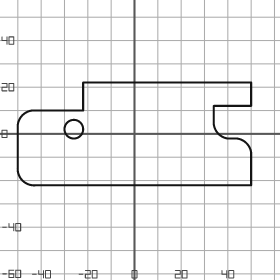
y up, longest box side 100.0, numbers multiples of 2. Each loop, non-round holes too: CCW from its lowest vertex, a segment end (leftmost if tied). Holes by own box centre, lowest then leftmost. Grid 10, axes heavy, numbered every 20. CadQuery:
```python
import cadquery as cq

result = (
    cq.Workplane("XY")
    .moveTo(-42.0, -22.0)
    .lineTo(50.0, -22.0)
    .lineTo(50.0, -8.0)
    .threePointArc((48.0, -4.0), (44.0, -2.0))
    .lineTo(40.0, -2.0)
    .threePointArc((36.0, 0.0), (34.0, 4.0))
    .lineTo(34.0, 12.0)
    .lineTo(50.0, 12.0)
    .lineTo(50.0, 22.0)
    .lineTo(-22.0, 22.0)
    .lineTo(-22.0, 10.0)
    .lineTo(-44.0, 10.0)
    .threePointArc((-48.0, 8.0), (-50.0, 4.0))
    .lineTo(-50.0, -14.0)
    .threePointArc((-48.0, -20.0), (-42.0, -22.0))
    .close()
    .moveTo(-26.0, 2.0)
    .circle(4.0)
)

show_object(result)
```